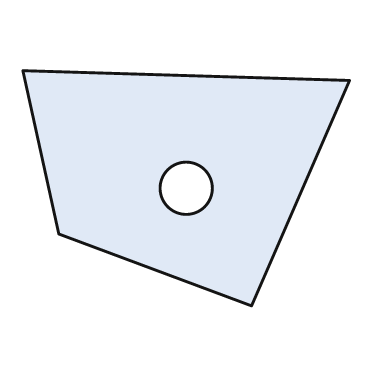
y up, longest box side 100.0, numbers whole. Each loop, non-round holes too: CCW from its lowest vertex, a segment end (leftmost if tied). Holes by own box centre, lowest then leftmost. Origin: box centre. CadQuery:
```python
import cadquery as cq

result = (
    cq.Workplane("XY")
    .moveTo(20.0, -36.0)
    .lineTo(50.0, 33.0)
    .lineTo(-50.0, 36.0)
    .lineTo(-39.0, -14.0)
    .close()
    .moveTo(0.0, 0.0)
    .circle(8.0)
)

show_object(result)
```